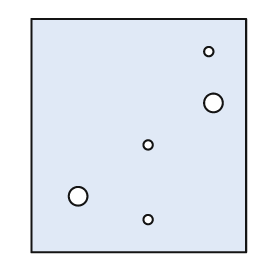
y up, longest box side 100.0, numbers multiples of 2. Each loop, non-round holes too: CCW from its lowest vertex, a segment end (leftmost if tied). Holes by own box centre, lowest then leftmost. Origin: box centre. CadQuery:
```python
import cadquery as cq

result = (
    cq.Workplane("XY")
    .moveTo(-46.0, -50.0)
    .lineTo(46.0, -50.0)
    .lineTo(46.0, 50.0)
    .lineTo(-46.0, 50.0)
    .close()
    .moveTo(4.0, -36.0)
    .circle(2.0)
    .moveTo(-26.0, -26.0)
    .circle(4.0)
    .moveTo(4.0, -4.0)
    .circle(2.0)
    .moveTo(32.0, 14.0)
    .circle(4.0)
    .moveTo(30.0, 36.0)
    .circle(2.0)
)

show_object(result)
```